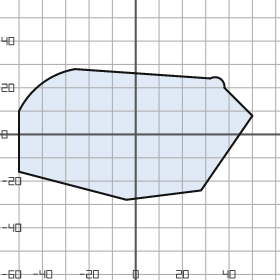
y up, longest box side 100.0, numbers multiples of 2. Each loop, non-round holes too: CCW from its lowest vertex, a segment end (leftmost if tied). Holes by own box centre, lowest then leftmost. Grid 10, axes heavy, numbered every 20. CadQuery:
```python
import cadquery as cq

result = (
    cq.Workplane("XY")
    .moveTo(-4.0, -28.0)
    .lineTo(28.0, -24.0)
    .lineTo(50.0, 8.0)
    .lineTo(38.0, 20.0)
    .threePointArc((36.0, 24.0), (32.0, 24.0))
    .lineTo(-26.0, 28.0)
    .threePointArc((-40.0, 22.0), (-50.0, 10.0))
    .lineTo(-50.0, -16.0)
    .close()
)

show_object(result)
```